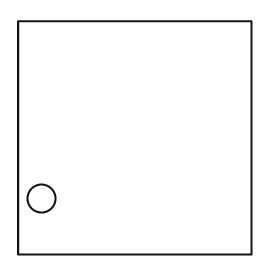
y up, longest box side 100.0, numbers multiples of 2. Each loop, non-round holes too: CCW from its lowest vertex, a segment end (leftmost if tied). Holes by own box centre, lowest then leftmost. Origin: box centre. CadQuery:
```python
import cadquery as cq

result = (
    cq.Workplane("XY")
    .moveTo(-50.0, -50.0)
    .lineTo(50.0, -50.0)
    .lineTo(50.0, 50.0)
    .lineTo(-50.0, 50.0)
    .close()
    .moveTo(-40.0, -26.0)
    .circle(6.0)
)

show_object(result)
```